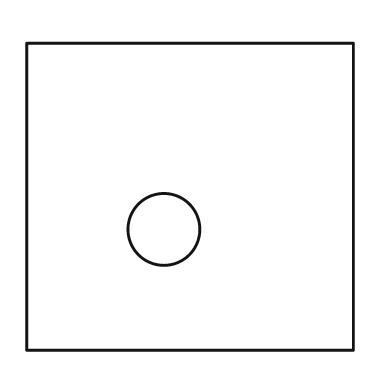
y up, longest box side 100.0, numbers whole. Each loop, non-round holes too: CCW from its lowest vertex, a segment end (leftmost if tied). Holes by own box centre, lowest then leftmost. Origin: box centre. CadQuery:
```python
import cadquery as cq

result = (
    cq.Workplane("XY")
    .moveTo(-50.0, -47.0)
    .lineTo(50.0, -47.0)
    .lineTo(50.0, 47.0)
    .lineTo(-50.0, 47.0)
    .close()
    .moveTo(-8.0, -10.0)
    .circle(11.0)
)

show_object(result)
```